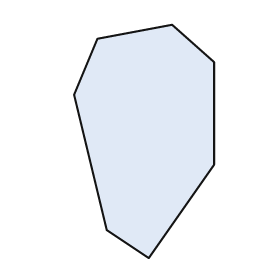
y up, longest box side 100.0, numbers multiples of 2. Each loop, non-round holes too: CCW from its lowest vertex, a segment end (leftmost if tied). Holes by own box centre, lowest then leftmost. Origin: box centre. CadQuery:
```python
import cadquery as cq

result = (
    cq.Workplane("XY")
    .moveTo(2.0, -50.0)
    .lineTo(30.0, -10.0)
    .lineTo(30.0, 34.0)
    .lineTo(12.0, 50.0)
    .lineTo(-20.0, 44.0)
    .lineTo(-30.0, 20.0)
    .lineTo(-16.0, -38.0)
    .close()
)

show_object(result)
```